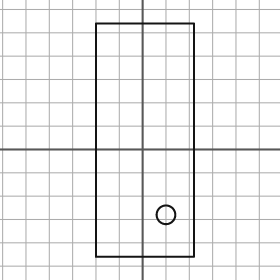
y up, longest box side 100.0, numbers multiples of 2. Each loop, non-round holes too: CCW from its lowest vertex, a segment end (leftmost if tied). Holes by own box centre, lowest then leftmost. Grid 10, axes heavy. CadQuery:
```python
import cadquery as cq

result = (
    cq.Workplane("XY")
    .moveTo(-20.0, -46.0)
    .lineTo(22.0, -46.0)
    .lineTo(22.0, 54.0)
    .lineTo(-20.0, 54.0)
    .close()
    .moveTo(10.0, -28.0)
    .circle(4.0)
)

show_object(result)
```